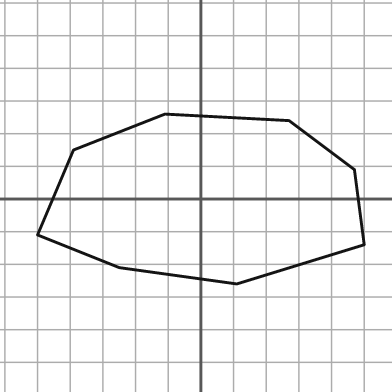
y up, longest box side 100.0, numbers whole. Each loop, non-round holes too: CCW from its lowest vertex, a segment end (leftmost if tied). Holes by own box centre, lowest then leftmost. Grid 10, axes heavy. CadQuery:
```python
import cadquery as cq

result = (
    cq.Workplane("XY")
    .moveTo(11.0, -26.0)
    .lineTo(50.0, -14.0)
    .lineTo(47.0, 9.0)
    .lineTo(27.0, 24.0)
    .lineTo(-11.0, 26.0)
    .lineTo(-39.0, 15.0)
    .lineTo(-50.0, -11.0)
    .lineTo(-25.0, -21.0)
    .close()
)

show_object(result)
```